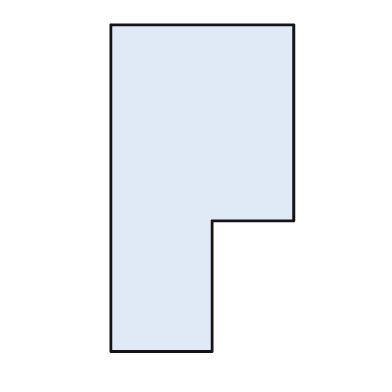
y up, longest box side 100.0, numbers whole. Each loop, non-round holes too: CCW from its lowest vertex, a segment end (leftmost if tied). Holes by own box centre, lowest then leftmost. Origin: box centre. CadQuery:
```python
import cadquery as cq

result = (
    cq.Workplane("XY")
    .moveTo(-28.0, -50.0)
    .lineTo(3.0, -50.0)
    .lineTo(3.0, -10.0)
    .lineTo(28.0, -10.0)
    .lineTo(28.0, 50.0)
    .lineTo(-28.0, 50.0)
    .close()
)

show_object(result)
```